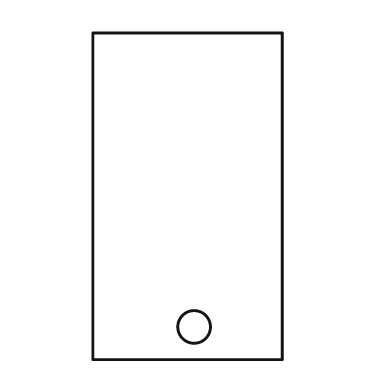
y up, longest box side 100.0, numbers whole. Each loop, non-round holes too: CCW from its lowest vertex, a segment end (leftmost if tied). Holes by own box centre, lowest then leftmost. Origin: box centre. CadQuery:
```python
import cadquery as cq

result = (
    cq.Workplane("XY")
    .moveTo(-29.0, -50.0)
    .lineTo(29.0, -50.0)
    .lineTo(29.0, 50.0)
    .lineTo(-29.0, 50.0)
    .close()
    .moveTo(2.0, -40.0)
    .circle(5.0)
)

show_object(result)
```